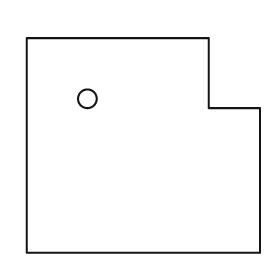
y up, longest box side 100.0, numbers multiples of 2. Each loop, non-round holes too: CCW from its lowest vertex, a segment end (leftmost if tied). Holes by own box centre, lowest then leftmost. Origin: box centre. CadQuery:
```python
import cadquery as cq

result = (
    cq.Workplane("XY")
    .moveTo(-50.0, -46.0)
    .lineTo(50.0, -46.0)
    .lineTo(50.0, 16.0)
    .lineTo(28.0, 16.0)
    .lineTo(28.0, 46.0)
    .lineTo(-50.0, 46.0)
    .close()
    .moveTo(-24.0, 20.0)
    .circle(4.0)
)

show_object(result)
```